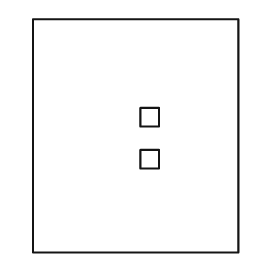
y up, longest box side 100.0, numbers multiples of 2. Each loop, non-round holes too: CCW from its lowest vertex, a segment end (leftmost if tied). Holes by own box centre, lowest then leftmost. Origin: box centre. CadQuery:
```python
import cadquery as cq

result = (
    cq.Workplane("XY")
    .moveTo(-44.0, -50.0)
    .lineTo(44.0, -50.0)
    .lineTo(44.0, 50.0)
    .lineTo(-44.0, 50.0)
    .close()
    .moveTo(2.0, -14.0)
    .lineTo(10.0, -14.0)
    .lineTo(10.0, -6.0)
    .lineTo(2.0, -6.0)
    .close()
    .moveTo(2.0, 4.0)
    .lineTo(10.0, 4.0)
    .lineTo(10.0, 12.0)
    .lineTo(2.0, 12.0)
    .close()
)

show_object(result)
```